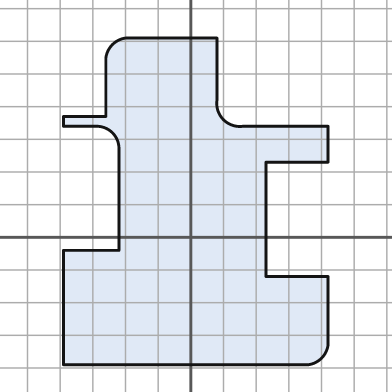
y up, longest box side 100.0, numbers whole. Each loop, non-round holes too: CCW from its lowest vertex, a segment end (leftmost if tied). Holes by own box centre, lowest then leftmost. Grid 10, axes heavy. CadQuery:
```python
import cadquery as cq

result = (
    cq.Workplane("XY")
    .moveTo(-39.0, -39.0)
    .lineTo(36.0, -39.0)
    .threePointArc((40.0, -37.0), (42.0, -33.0))
    .lineTo(42.0, -12.0)
    .lineTo(23.0, -12.0)
    .lineTo(23.0, 23.0)
    .lineTo(42.0, 23.0)
    .lineTo(42.0, 34.0)
    .lineTo(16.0, 34.0)
    .threePointArc((10.0, 36.0), (8.0, 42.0))
    .lineTo(8.0, 61.0)
    .lineTo(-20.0, 61.0)
    .threePointArc((-24.0, 59.0), (-26.0, 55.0))
    .lineTo(-26.0, 37.0)
    .lineTo(-39.0, 37.0)
    .lineTo(-39.0, 34.0)
    .lineTo(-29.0, 34.0)
    .threePointArc((-24.0, 32.0), (-22.0, 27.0))
    .lineTo(-22.0, -4.0)
    .lineTo(-39.0, -4.0)
    .close()
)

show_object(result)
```